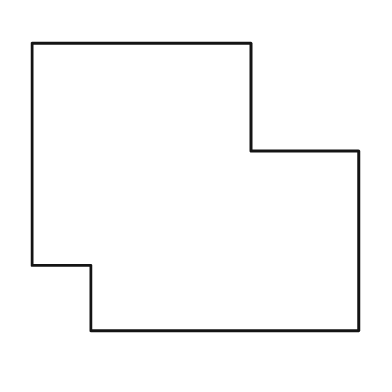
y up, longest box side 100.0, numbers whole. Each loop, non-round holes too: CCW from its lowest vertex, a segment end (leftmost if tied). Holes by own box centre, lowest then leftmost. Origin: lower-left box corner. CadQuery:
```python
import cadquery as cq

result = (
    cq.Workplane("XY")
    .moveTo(18.0, 0.0)
    .lineTo(100.0, 0.0)
    .lineTo(100.0, 55.0)
    .lineTo(67.0, 55.0)
    .lineTo(67.0, 88.0)
    .lineTo(0.0, 88.0)
    .lineTo(0.0, 20.0)
    .lineTo(18.0, 20.0)
    .close()
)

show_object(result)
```